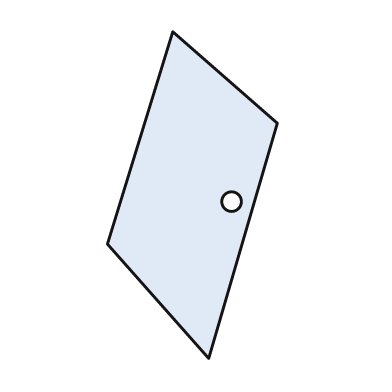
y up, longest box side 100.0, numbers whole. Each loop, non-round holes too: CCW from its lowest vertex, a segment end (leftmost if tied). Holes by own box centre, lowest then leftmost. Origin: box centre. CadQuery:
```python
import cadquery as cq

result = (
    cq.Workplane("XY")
    .moveTo(5.0, -50.0)
    .lineTo(26.0, 22.0)
    .lineTo(-6.0, 50.0)
    .lineTo(-26.0, -15.0)
    .close()
    .moveTo(12.0, -2.0)
    .circle(3.0)
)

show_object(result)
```